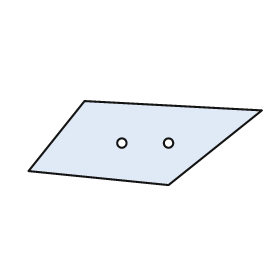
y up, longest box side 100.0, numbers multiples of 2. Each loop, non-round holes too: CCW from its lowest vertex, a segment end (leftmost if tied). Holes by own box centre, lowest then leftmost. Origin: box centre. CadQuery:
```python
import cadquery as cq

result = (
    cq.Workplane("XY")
    .moveTo(10.0, -18.0)
    .lineTo(50.0, 14.0)
    .lineTo(-26.0, 18.0)
    .lineTo(-50.0, -12.0)
    .close()
    .moveTo(-10.0, 0.0)
    .circle(2.0)
    .moveTo(10.0, 0.0)
    .circle(2.0)
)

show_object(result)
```